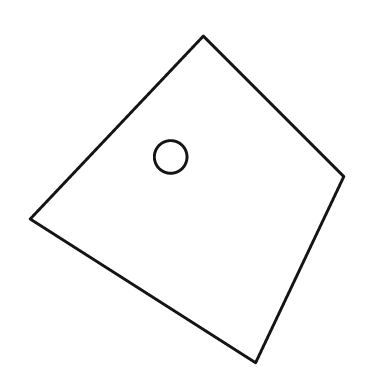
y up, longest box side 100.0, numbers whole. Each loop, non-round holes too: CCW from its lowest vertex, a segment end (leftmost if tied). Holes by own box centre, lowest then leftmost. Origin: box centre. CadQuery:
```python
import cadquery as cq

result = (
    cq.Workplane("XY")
    .moveTo(21.0, -50.0)
    .lineTo(48.0, 7.0)
    .lineTo(5.0, 50.0)
    .lineTo(-48.0, -6.0)
    .close()
    .moveTo(-5.0, 13.0)
    .circle(5.0)
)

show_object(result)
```